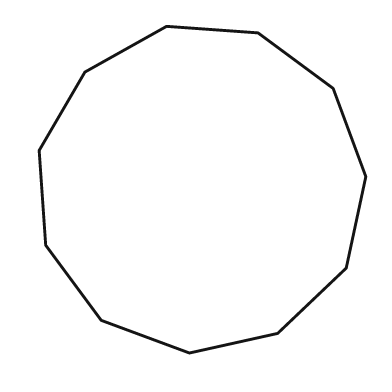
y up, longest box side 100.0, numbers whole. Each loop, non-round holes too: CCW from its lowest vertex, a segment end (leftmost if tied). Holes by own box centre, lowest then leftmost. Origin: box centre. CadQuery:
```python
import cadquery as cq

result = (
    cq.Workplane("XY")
    .moveTo(-4.0, -50.0)
    .lineTo(23.0, -44.0)
    .lineTo(44.0, -24.0)
    .lineTo(50.0, 4.0)
    .lineTo(40.0, 31.0)
    .lineTo(17.0, 48.0)
    .lineTo(-11.0, 50.0)
    .lineTo(-36.0, 36.0)
    .lineTo(-50.0, 12.0)
    .lineTo(-48.0, -17.0)
    .lineTo(-31.0, -40.0)
    .close()
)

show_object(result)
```